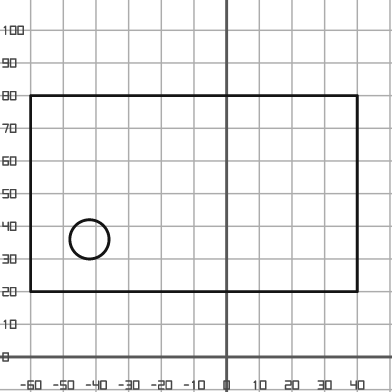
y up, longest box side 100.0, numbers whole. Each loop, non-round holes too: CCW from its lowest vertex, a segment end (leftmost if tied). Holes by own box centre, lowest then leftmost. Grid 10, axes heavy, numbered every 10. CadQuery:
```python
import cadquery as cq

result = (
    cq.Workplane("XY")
    .moveTo(-60.0, 20.0)
    .lineTo(40.0, 20.0)
    .lineTo(40.0, 80.0)
    .lineTo(-60.0, 80.0)
    .close()
    .moveTo(-42.0, 36.0)
    .circle(6.0)
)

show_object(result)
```